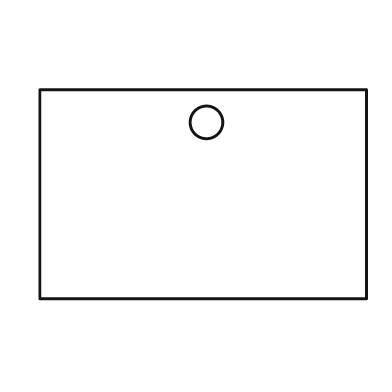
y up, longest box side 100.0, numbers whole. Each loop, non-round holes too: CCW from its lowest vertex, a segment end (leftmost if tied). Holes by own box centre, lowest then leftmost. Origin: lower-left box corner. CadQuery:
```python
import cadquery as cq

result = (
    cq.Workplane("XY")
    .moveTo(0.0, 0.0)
    .lineTo(100.0, 0.0)
    .lineTo(100.0, 64.0)
    .lineTo(0.0, 64.0)
    .close()
    .moveTo(51.0, 54.0)
    .circle(5.0)
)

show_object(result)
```